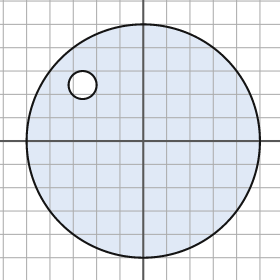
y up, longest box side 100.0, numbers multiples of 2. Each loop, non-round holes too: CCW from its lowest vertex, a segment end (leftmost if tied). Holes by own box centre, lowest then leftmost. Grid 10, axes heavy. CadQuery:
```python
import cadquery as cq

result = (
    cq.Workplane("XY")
    .moveTo(0.0, 0.0)
    .circle(50.0)
    .moveTo(-26.0, 24.0)
    .circle(6.0)
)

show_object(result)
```